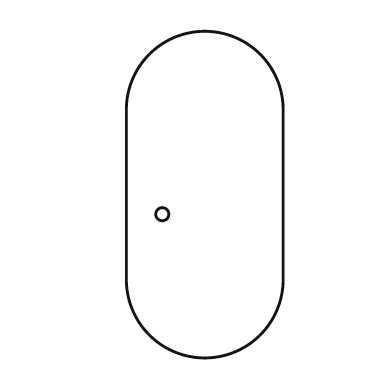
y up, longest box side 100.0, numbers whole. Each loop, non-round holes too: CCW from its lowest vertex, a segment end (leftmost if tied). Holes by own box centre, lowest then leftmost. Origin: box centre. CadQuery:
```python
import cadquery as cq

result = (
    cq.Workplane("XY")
    .moveTo(-24.0, -26.0)
    .threePointArc((0.0, -50.0), (24.0, -26.0))
    .lineTo(24.0, 26.0)
    .threePointArc((0.0, 50.0), (-24.0, 26.0))
    .close()
    .moveTo(-13.0, -6.0)
    .circle(2.0)
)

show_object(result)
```